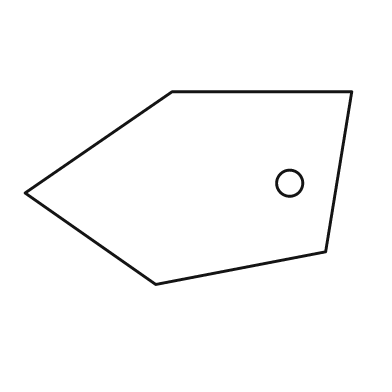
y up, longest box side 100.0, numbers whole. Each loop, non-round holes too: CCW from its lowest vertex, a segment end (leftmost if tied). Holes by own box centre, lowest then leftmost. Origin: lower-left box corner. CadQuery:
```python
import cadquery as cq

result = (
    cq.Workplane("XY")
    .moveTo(40.0, 0.0)
    .lineTo(92.0, 10.0)
    .lineTo(100.0, 59.0)
    .lineTo(45.0, 59.0)
    .lineTo(0.0, 28.0)
    .close()
    .moveTo(81.0, 31.0)
    .circle(4.0)
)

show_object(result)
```